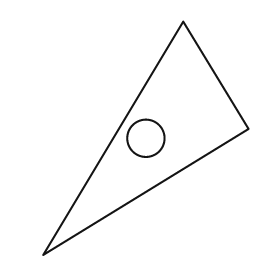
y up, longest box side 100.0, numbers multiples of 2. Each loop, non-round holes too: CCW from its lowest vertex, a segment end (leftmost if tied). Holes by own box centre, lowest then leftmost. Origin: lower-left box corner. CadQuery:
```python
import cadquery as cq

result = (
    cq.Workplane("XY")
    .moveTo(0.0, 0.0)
    .lineTo(88.0, 54.0)
    .lineTo(60.0, 100.0)
    .close()
    .moveTo(44.0, 50.0)
    .circle(8.0)
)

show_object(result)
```